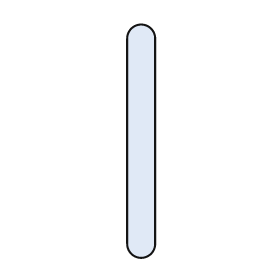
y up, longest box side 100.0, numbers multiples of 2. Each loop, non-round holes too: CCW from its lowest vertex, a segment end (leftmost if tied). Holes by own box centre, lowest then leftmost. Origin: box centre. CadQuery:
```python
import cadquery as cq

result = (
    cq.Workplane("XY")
    .moveTo(-6.0, -44.0)
    .threePointArc((0.0, -50.0), (6.0, -44.0))
    .lineTo(6.0, 44.0)
    .threePointArc((0.0, 50.0), (-6.0, 44.0))
    .close()
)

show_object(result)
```